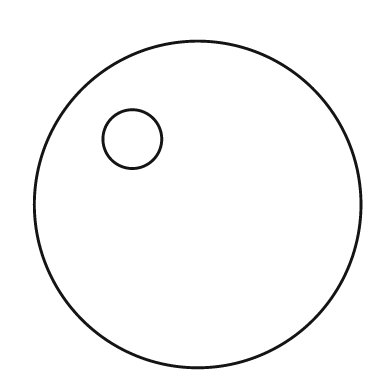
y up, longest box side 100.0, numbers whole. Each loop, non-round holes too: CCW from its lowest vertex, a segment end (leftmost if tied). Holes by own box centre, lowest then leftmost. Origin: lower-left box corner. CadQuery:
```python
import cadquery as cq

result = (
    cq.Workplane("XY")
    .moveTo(50.0, 50.0)
    .circle(50.0)
    .moveTo(30.0, 70.0)
    .circle(9.0)
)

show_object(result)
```